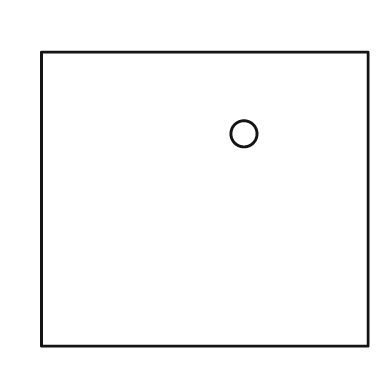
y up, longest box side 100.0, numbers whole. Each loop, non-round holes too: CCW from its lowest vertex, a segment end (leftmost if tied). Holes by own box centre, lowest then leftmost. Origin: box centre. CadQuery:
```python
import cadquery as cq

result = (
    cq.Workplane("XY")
    .moveTo(-50.0, -45.0)
    .lineTo(50.0, -45.0)
    .lineTo(50.0, 45.0)
    .lineTo(-50.0, 45.0)
    .close()
    .moveTo(12.0, 20.0)
    .circle(4.0)
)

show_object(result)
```